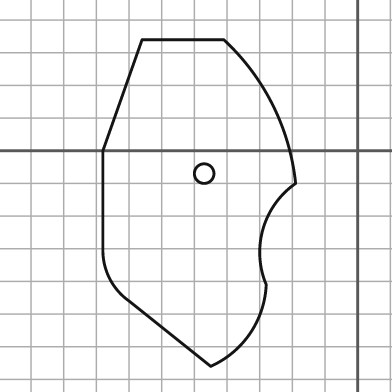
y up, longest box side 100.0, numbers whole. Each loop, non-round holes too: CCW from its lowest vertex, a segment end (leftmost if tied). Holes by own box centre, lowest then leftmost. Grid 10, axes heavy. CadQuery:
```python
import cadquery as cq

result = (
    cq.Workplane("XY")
    .moveTo(-45.0, -66.0)
    .threePointArc((-33.0, -56.0), (-28.0, -41.0))
    .threePointArc((-29.0, -24.0), (-19.0, -10.0))
    .threePointArc((-26.0, 14.0), (-41.0, 34.0))
    .lineTo(-66.0, 34.0)
    .lineTo(-78.0, 0.0)
    .lineTo(-78.0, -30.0)
    .threePointArc((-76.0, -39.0), (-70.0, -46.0))
    .close()
    .moveTo(-47.0, -7.0)
    .circle(3.0)
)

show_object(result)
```